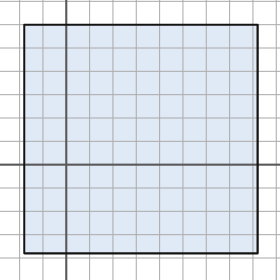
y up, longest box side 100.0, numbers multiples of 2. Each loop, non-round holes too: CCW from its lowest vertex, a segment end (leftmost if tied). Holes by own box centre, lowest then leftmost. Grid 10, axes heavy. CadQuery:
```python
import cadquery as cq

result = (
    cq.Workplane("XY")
    .moveTo(-18.0, -38.0)
    .lineTo(82.0, -38.0)
    .lineTo(82.0, 60.0)
    .lineTo(-18.0, 60.0)
    .close()
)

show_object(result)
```